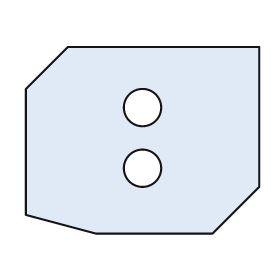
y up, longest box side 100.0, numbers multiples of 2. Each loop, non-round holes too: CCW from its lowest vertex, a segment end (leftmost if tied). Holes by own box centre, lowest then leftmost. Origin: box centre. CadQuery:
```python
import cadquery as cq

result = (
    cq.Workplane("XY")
    .moveTo(-20.0, -40.0)
    .lineTo(30.0, -40.0)
    .lineTo(50.0, -20.0)
    .lineTo(50.0, 40.0)
    .lineTo(-32.0, 40.0)
    .lineTo(-50.0, 22.0)
    .lineTo(-50.0, -32.0)
    .close()
    .moveTo(0.0, -12.0)
    .circle(8.0)
    .moveTo(0.0, 14.0)
    .circle(8.0)
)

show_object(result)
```